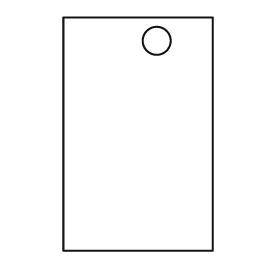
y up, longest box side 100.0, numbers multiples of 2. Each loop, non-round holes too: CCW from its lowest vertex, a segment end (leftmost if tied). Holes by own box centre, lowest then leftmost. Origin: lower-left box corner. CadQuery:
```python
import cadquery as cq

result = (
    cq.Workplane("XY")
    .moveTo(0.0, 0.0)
    .lineTo(64.0, 0.0)
    .lineTo(64.0, 100.0)
    .lineTo(0.0, 100.0)
    .close()
    .moveTo(40.0, 90.0)
    .circle(6.0)
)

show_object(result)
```